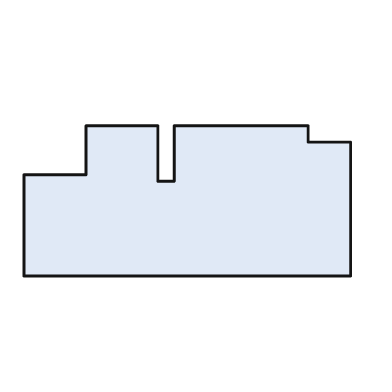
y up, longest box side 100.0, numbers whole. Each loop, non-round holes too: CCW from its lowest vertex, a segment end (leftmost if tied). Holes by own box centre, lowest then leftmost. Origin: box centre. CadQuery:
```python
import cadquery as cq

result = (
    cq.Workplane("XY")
    .moveTo(-50.0, -23.0)
    .lineTo(50.0, -23.0)
    .lineTo(50.0, 18.0)
    .lineTo(37.0, 18.0)
    .lineTo(37.0, 23.0)
    .lineTo(-4.0, 23.0)
    .lineTo(-4.0, 6.0)
    .lineTo(-9.0, 6.0)
    .lineTo(-9.0, 23.0)
    .lineTo(-31.0, 23.0)
    .lineTo(-31.0, 8.0)
    .lineTo(-50.0, 8.0)
    .close()
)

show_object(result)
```